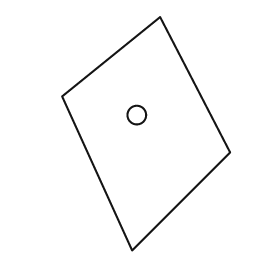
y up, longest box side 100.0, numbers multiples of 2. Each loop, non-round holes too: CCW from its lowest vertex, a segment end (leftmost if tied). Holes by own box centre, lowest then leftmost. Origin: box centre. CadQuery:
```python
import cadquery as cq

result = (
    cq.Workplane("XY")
    .moveTo(-6.0, -50.0)
    .lineTo(36.0, -8.0)
    .lineTo(6.0, 50.0)
    .lineTo(-36.0, 16.0)
    .close()
    .moveTo(-4.0, 8.0)
    .circle(4.0)
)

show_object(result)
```